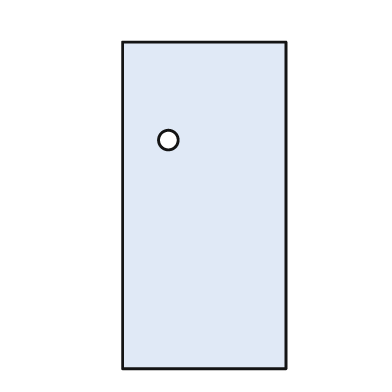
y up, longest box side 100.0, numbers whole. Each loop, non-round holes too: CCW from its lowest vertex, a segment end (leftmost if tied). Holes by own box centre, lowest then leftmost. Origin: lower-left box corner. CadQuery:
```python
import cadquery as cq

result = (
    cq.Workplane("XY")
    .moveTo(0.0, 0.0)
    .lineTo(50.0, 0.0)
    .lineTo(50.0, 100.0)
    .lineTo(0.0, 100.0)
    .close()
    .moveTo(14.0, 70.0)
    .circle(3.0)
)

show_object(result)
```